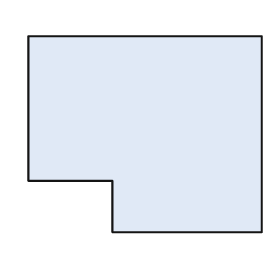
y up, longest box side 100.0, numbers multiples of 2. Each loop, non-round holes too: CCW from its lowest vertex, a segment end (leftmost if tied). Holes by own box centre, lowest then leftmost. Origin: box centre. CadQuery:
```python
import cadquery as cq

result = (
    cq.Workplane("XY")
    .moveTo(-14.0, -42.0)
    .lineTo(50.0, -42.0)
    .lineTo(50.0, 42.0)
    .lineTo(-50.0, 42.0)
    .lineTo(-50.0, -20.0)
    .lineTo(-14.0, -20.0)
    .close()
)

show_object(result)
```